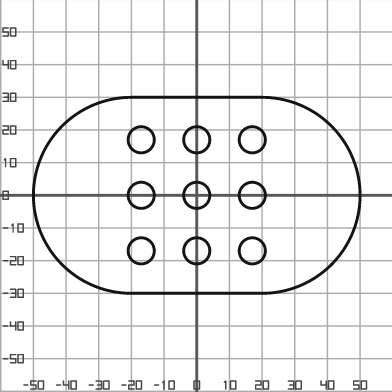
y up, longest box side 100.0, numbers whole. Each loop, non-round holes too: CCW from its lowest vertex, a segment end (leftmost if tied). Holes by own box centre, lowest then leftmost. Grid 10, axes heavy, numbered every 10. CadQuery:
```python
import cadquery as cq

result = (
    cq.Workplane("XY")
    .moveTo(-20.0, -30.0)
    .lineTo(20.0, -30.0)
    .threePointArc((50.0, 0.0), (20.0, 30.0))
    .lineTo(-20.0, 30.0)
    .threePointArc((-50.0, 0.0), (-20.0, -30.0))
    .close()
    .moveTo(-17.0, -17.0)
    .circle(4.0)
    .moveTo(0.0, -17.0)
    .circle(4.0)
    .moveTo(17.0, -17.0)
    .circle(4.0)
    .moveTo(-17.0, 0.0)
    .circle(4.0)
    .moveTo(0.0, 0.0)
    .circle(4.0)
    .moveTo(17.0, 0.0)
    .circle(4.0)
    .moveTo(-17.0, 17.0)
    .circle(4.0)
    .moveTo(0.0, 17.0)
    .circle(4.0)
    .moveTo(17.0, 17.0)
    .circle(4.0)
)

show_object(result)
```